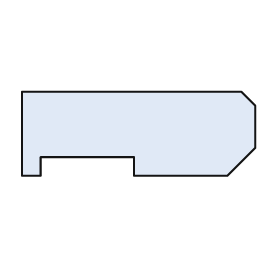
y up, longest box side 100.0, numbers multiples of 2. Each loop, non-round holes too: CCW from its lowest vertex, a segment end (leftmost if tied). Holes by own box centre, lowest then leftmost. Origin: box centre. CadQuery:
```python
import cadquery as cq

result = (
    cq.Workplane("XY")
    .moveTo(-50.0, -18.0)
    .lineTo(-42.0, -18.0)
    .lineTo(-42.0, -10.0)
    .lineTo(-2.0, -10.0)
    .lineTo(-2.0, -18.0)
    .lineTo(38.0, -18.0)
    .lineTo(50.0, -6.0)
    .lineTo(50.0, 12.0)
    .lineTo(44.0, 18.0)
    .lineTo(-50.0, 18.0)
    .close()
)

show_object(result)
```